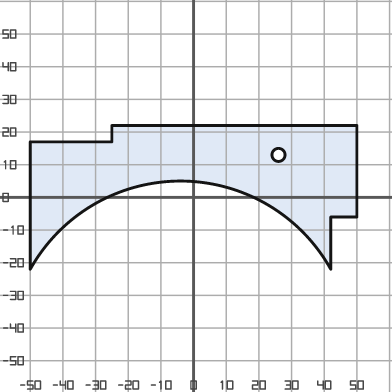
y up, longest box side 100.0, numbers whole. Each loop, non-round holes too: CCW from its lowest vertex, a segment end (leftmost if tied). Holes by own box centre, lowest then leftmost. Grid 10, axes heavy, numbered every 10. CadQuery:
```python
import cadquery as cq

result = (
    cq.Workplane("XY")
    .moveTo(-50.0, -22.0)
    .threePointArc((-4.0, 5.0), (42.0, -22.0))
    .lineTo(42.0, -6.0)
    .lineTo(50.0, -6.0)
    .lineTo(50.0, 22.0)
    .lineTo(-25.0, 22.0)
    .lineTo(-25.0, 17.0)
    .lineTo(-50.0, 17.0)
    .close()
    .moveTo(26.0, 13.0)
    .circle(2.0)
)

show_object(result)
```